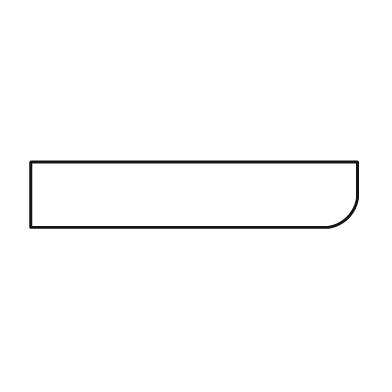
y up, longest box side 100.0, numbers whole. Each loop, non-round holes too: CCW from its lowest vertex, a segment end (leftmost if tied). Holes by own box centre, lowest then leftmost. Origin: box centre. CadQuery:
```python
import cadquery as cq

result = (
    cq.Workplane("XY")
    .moveTo(-50.0, -10.0)
    .lineTo(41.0, -10.0)
    .threePointArc((47.0, -7.0), (50.0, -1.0))
    .lineTo(50.0, 10.0)
    .lineTo(-50.0, 10.0)
    .close()
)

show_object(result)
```